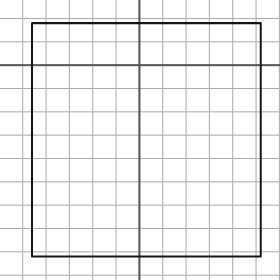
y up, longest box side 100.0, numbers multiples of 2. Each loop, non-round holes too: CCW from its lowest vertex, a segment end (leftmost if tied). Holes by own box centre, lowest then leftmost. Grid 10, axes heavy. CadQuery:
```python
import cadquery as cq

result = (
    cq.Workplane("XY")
    .moveTo(-46.0, -82.0)
    .lineTo(52.0, -82.0)
    .lineTo(52.0, 18.0)
    .lineTo(-46.0, 18.0)
    .close()
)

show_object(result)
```